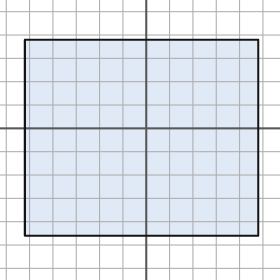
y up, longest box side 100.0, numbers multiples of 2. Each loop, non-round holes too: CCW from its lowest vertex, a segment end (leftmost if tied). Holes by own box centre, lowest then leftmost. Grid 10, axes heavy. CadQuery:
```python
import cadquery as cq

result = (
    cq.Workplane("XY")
    .moveTo(-52.0, -46.0)
    .lineTo(48.0, -46.0)
    .lineTo(48.0, 38.0)
    .lineTo(-52.0, 38.0)
    .close()
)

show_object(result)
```